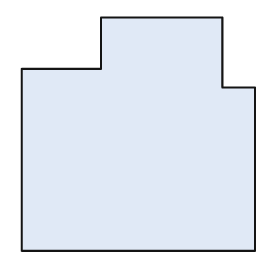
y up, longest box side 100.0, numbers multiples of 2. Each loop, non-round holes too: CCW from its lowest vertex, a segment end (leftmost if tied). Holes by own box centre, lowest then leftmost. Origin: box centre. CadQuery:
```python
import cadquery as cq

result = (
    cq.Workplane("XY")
    .moveTo(-50.0, -50.0)
    .lineTo(50.0, -50.0)
    .lineTo(50.0, 20.0)
    .lineTo(36.0, 20.0)
    .lineTo(36.0, 50.0)
    .lineTo(-16.0, 50.0)
    .lineTo(-16.0, 28.0)
    .lineTo(-50.0, 28.0)
    .close()
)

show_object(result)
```